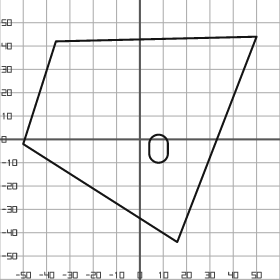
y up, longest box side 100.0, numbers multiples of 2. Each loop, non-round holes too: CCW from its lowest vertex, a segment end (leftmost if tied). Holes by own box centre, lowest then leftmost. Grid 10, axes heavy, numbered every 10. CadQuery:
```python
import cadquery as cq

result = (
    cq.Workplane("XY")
    .moveTo(16.0, -44.0)
    .lineTo(50.0, 44.0)
    .lineTo(-36.0, 42.0)
    .lineTo(-50.0, -2.0)
    .close()
    .moveTo(4.0, -6.0)
    .threePointArc((8.0, -10.0), (12.0, -6.0))
    .lineTo(12.0, -2.0)
    .threePointArc((8.0, 2.0), (4.0, -2.0))
    .close()
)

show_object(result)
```